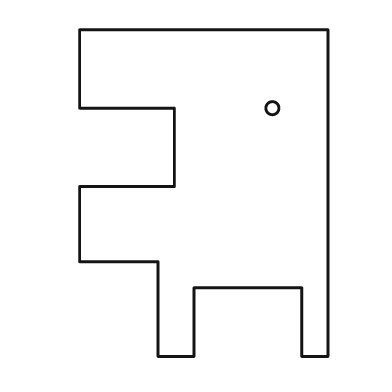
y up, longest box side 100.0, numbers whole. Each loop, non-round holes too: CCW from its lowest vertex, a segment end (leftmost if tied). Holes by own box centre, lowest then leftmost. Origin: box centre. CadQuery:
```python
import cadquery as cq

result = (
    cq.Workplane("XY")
    .moveTo(-14.0, -50.0)
    .lineTo(-3.0, -50.0)
    .lineTo(-3.0, -29.0)
    .lineTo(30.0, -29.0)
    .lineTo(30.0, -50.0)
    .lineTo(38.0, -50.0)
    .lineTo(38.0, 50.0)
    .lineTo(-38.0, 50.0)
    .lineTo(-38.0, 26.0)
    .lineTo(-9.0, 26.0)
    .lineTo(-9.0, 2.0)
    .lineTo(-38.0, 2.0)
    .lineTo(-38.0, -21.0)
    .lineTo(-14.0, -21.0)
    .close()
    .moveTo(21.0, 26.0)
    .circle(2.0)
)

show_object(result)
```